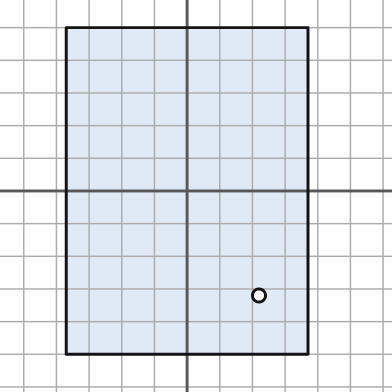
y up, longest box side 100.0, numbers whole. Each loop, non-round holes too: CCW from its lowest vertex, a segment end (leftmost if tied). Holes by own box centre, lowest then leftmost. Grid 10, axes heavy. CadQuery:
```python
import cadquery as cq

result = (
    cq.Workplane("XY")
    .moveTo(-37.0, -50.0)
    .lineTo(37.0, -50.0)
    .lineTo(37.0, 50.0)
    .lineTo(-37.0, 50.0)
    .close()
    .moveTo(22.0, -32.0)
    .circle(2.0)
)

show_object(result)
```